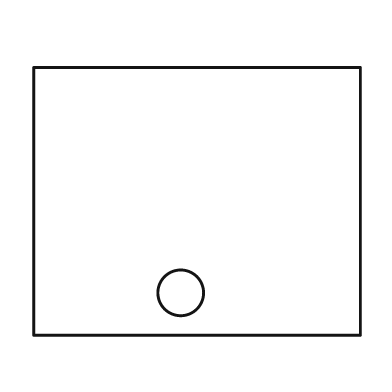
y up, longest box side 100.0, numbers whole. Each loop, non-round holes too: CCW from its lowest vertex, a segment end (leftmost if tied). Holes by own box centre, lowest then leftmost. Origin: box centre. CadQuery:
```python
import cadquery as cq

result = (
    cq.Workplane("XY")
    .moveTo(-50.0, -41.0)
    .lineTo(50.0, -41.0)
    .lineTo(50.0, 41.0)
    .lineTo(-50.0, 41.0)
    .close()
    .moveTo(-5.0, -28.0)
    .circle(7.0)
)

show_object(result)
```